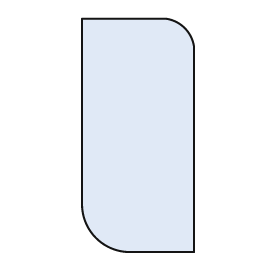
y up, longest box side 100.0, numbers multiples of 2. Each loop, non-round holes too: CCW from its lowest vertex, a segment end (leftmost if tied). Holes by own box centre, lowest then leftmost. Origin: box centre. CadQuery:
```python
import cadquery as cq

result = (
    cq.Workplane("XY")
    .moveTo(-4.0, -50.0)
    .lineTo(24.0, -50.0)
    .lineTo(24.0, 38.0)
    .threePointArc((20.0, 46.0), (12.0, 50.0))
    .lineTo(-24.0, 50.0)
    .lineTo(-24.0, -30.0)
    .threePointArc((-18.0, -44.0), (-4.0, -50.0))
    .close()
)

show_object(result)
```